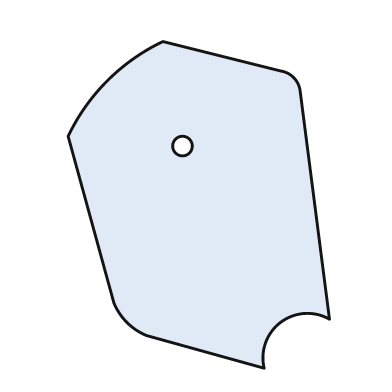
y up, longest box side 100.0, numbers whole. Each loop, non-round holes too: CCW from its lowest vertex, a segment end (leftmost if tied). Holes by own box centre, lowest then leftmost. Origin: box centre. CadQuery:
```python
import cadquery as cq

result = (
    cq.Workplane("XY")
    .moveTo(20.0, -50.0)
    .threePointArc((25.0, -36.0), (40.0, -35.0))
    .lineTo(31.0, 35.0)
    .threePointArc((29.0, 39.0), (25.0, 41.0))
    .lineTo(-11.0, 50.0)
    .threePointArc((-28.0, 38.0), (-40.0, 21.0))
    .lineTo(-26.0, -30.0)
    .threePointArc((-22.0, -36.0), (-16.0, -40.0))
    .close()
    .moveTo(-5.0, 18.0)
    .circle(3.0)
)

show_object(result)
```